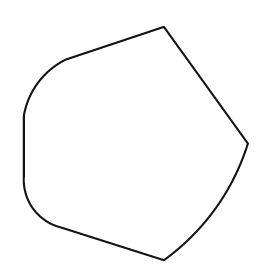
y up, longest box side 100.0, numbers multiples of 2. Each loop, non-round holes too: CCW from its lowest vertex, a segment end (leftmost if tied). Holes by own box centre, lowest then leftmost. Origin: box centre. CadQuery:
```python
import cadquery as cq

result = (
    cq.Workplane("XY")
    .moveTo(12.0, -50.0)
    .threePointArc((34.0, -28.0), (48.0, 0.0))
    .lineTo(12.0, 50.0)
    .lineTo(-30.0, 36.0)
    .threePointArc((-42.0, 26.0), (-48.0, 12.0))
    .lineTo(-48.0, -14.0)
    .threePointArc((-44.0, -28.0), (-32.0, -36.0))
    .close()
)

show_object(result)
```